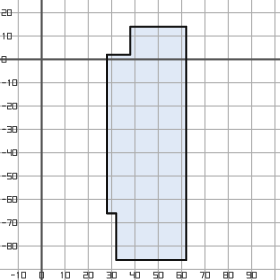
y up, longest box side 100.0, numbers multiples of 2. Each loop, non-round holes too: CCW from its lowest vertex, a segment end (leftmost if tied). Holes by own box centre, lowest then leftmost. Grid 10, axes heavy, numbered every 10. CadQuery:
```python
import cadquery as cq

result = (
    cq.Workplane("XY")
    .moveTo(32.0, -86.0)
    .lineTo(62.0, -86.0)
    .lineTo(62.0, 14.0)
    .lineTo(38.0, 14.0)
    .lineTo(38.0, 2.0)
    .lineTo(28.0, 2.0)
    .lineTo(28.0, -66.0)
    .lineTo(32.0, -66.0)
    .close()
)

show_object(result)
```